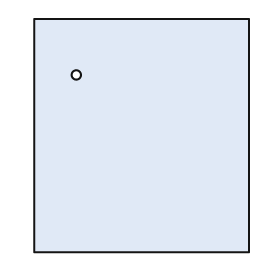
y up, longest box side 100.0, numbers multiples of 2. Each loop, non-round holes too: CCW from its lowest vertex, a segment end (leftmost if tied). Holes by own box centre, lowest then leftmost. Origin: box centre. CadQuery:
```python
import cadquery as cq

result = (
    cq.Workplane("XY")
    .moveTo(-46.0, -50.0)
    .lineTo(46.0, -50.0)
    .lineTo(46.0, 50.0)
    .lineTo(-46.0, 50.0)
    .close()
    .moveTo(-28.0, 26.0)
    .circle(2.0)
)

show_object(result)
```